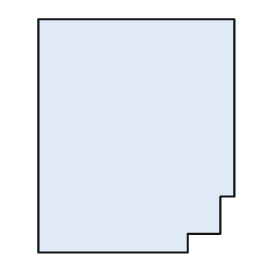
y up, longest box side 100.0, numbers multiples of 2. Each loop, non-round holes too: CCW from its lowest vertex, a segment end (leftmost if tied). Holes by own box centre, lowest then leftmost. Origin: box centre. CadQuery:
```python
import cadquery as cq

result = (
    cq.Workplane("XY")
    .moveTo(-42.0, -50.0)
    .lineTo(22.0, -50.0)
    .lineTo(22.0, -42.0)
    .lineTo(36.0, -42.0)
    .lineTo(36.0, -26.0)
    .lineTo(42.0, -26.0)
    .lineTo(42.0, 50.0)
    .lineTo(-42.0, 50.0)
    .close()
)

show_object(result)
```